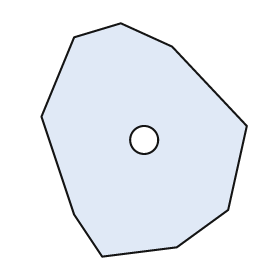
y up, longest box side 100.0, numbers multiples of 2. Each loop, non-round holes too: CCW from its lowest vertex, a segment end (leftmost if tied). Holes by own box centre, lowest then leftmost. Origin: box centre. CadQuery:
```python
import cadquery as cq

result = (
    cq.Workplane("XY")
    .moveTo(-18.0, -50.0)
    .lineTo(14.0, -46.0)
    .lineTo(36.0, -30.0)
    .lineTo(44.0, 6.0)
    .lineTo(12.0, 40.0)
    .lineTo(-10.0, 50.0)
    .lineTo(-30.0, 44.0)
    .lineTo(-44.0, 10.0)
    .lineTo(-30.0, -32.0)
    .close()
    .moveTo(0.0, 0.0)
    .circle(6.0)
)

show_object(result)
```